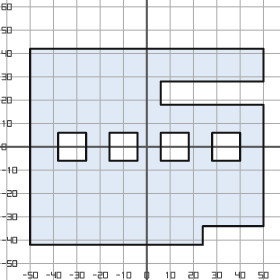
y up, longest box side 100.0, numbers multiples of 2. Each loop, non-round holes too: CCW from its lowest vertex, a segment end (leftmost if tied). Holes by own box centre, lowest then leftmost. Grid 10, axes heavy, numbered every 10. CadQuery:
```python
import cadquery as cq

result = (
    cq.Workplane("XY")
    .moveTo(-50.0, -42.0)
    .lineTo(24.0, -42.0)
    .lineTo(24.0, -34.0)
    .lineTo(50.0, -34.0)
    .lineTo(50.0, 18.0)
    .lineTo(6.0, 18.0)
    .lineTo(6.0, 28.0)
    .lineTo(50.0, 28.0)
    .lineTo(50.0, 42.0)
    .lineTo(-50.0, 42.0)
    .close()
    .moveTo(-38.0, -6.0)
    .lineTo(-26.0, -6.0)
    .lineTo(-26.0, 6.0)
    .lineTo(-38.0, 6.0)
    .close()
    .moveTo(-16.0, -6.0)
    .lineTo(-4.0, -6.0)
    .lineTo(-4.0, 6.0)
    .lineTo(-16.0, 6.0)
    .close()
    .moveTo(6.0, -6.0)
    .lineTo(18.0, -6.0)
    .lineTo(18.0, 6.0)
    .lineTo(6.0, 6.0)
    .close()
    .moveTo(28.0, -6.0)
    .lineTo(40.0, -6.0)
    .lineTo(40.0, 6.0)
    .lineTo(28.0, 6.0)
    .close()
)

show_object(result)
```